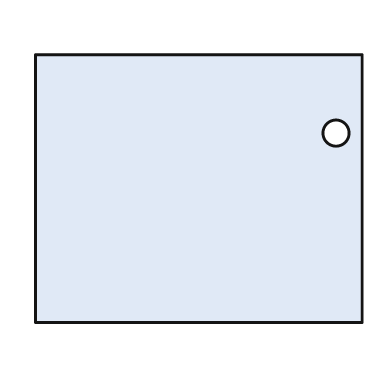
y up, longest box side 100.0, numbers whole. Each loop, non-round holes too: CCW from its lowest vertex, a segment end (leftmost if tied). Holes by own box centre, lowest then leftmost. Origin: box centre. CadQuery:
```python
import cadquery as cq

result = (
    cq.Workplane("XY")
    .moveTo(-50.0, -41.0)
    .lineTo(50.0, -41.0)
    .lineTo(50.0, 41.0)
    .lineTo(-50.0, 41.0)
    .close()
    .moveTo(42.0, 17.0)
    .circle(4.0)
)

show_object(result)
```